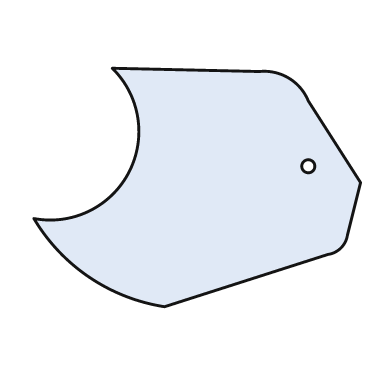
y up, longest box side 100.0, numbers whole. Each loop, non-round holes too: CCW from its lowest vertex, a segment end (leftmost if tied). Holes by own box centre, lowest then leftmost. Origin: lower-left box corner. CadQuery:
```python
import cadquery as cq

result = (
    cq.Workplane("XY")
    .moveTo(40.0, 0.0)
    .lineTo(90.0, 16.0)
    .threePointArc((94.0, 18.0), (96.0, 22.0))
    .lineTo(100.0, 38.0)
    .lineTo(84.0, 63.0)
    .threePointArc((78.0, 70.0), (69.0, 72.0))
    .lineTo(24.0, 73.0)
    .threePointArc((29.0, 41.0), (0.0, 27.0))
    .threePointArc((17.0, 9.0), (40.0, 0.0))
    .close()
    .moveTo(84.0, 43.0)
    .circle(2.0)
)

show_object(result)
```